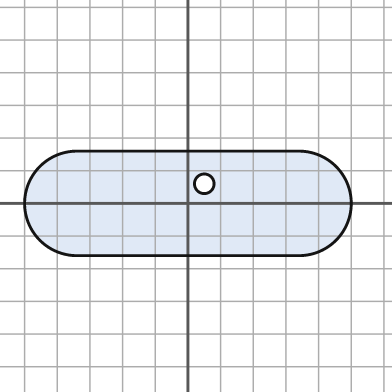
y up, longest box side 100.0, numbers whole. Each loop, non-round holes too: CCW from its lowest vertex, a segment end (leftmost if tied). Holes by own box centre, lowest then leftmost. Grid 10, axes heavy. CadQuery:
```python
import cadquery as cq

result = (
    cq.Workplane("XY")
    .moveTo(-34.0, -16.0)
    .lineTo(34.0, -16.0)
    .threePointArc((50.0, 0.0), (34.0, 16.0))
    .lineTo(-34.0, 16.0)
    .threePointArc((-50.0, 0.0), (-34.0, -16.0))
    .close()
    .moveTo(5.0, 6.0)
    .circle(3.0)
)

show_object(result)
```